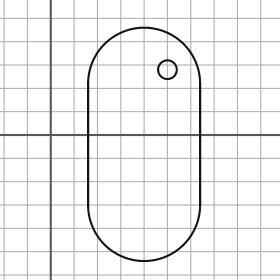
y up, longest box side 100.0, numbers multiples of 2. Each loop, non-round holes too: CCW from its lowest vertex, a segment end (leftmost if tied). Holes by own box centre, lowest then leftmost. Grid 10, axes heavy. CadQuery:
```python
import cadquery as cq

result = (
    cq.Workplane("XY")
    .moveTo(16.0, -30.0)
    .threePointArc((40.0, -54.0), (64.0, -30.0))
    .lineTo(64.0, 22.0)
    .threePointArc((40.0, 46.0), (16.0, 22.0))
    .close()
    .moveTo(50.0, 28.0)
    .circle(4.0)
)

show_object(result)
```